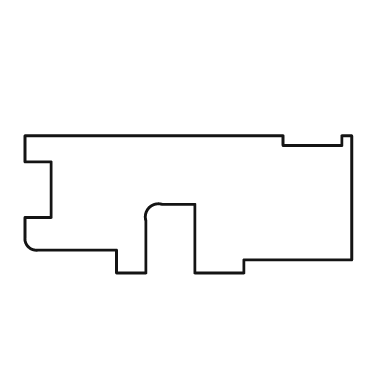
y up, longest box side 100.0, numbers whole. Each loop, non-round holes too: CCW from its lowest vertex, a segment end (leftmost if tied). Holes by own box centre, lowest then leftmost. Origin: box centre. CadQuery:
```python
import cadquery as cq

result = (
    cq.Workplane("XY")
    .moveTo(-22.0, -21.0)
    .lineTo(-13.0, -21.0)
    .lineTo(-13.0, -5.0)
    .threePointArc((-12.0, -1.0), (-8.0, 0.0))
    .lineTo(2.0, 0.0)
    .lineTo(2.0, -21.0)
    .lineTo(17.0, -21.0)
    .lineTo(17.0, -17.0)
    .lineTo(50.0, -17.0)
    .lineTo(50.0, 21.0)
    .lineTo(47.0, 21.0)
    .lineTo(47.0, 18.0)
    .lineTo(29.0, 18.0)
    .lineTo(29.0, 21.0)
    .lineTo(-50.0, 21.0)
    .lineTo(-50.0, 13.0)
    .lineTo(-42.0, 13.0)
    .lineTo(-42.0, -4.0)
    .lineTo(-50.0, -4.0)
    .lineTo(-50.0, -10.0)
    .threePointArc((-49.0, -13.0), (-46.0, -14.0))
    .lineTo(-22.0, -14.0)
    .close()
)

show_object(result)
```